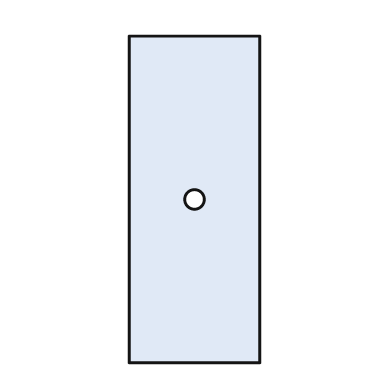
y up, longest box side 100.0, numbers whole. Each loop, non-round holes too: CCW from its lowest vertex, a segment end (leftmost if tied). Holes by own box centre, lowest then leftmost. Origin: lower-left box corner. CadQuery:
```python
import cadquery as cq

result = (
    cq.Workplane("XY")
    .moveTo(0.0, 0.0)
    .lineTo(40.0, 0.0)
    .lineTo(40.0, 100.0)
    .lineTo(0.0, 100.0)
    .close()
    .moveTo(20.0, 50.0)
    .circle(3.0)
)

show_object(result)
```